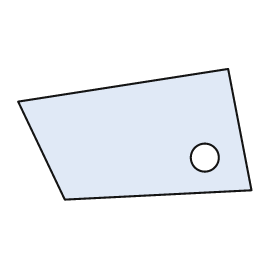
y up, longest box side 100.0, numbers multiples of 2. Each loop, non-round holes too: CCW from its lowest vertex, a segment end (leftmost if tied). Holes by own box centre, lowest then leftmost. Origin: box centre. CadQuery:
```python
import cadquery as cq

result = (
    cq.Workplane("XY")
    .moveTo(-30.0, -28.0)
    .lineTo(50.0, -24.0)
    .lineTo(40.0, 28.0)
    .lineTo(-50.0, 14.0)
    .close()
    .moveTo(30.0, -10.0)
    .circle(6.0)
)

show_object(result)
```